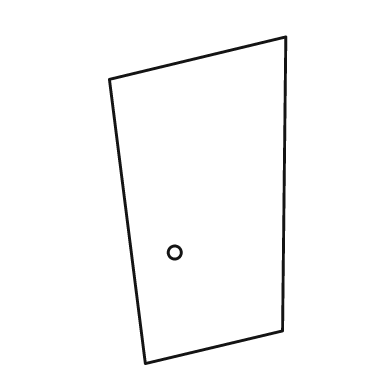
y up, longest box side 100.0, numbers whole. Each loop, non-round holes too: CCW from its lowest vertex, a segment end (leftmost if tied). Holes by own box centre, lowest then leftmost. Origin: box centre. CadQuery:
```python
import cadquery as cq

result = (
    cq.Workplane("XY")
    .moveTo(-16.0, -50.0)
    .lineTo(26.0, -40.0)
    .lineTo(27.0, 50.0)
    .lineTo(-27.0, 37.0)
    .close()
    .moveTo(-7.0, -16.0)
    .circle(2.0)
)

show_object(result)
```